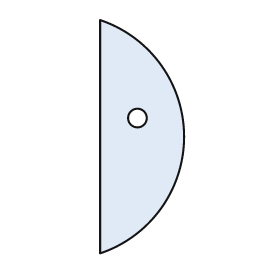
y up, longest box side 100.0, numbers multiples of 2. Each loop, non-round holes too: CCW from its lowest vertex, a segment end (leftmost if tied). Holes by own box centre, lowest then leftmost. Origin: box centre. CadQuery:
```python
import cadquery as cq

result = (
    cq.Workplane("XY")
    .moveTo(-18.0, -50.0)
    .threePointArc((18.0, 0.0), (-18.0, 50.0))
    .close()
    .moveTo(-2.0, 8.0)
    .circle(4.0)
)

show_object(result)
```